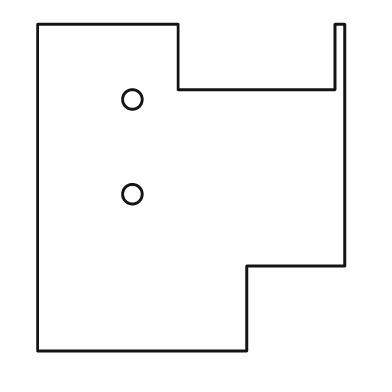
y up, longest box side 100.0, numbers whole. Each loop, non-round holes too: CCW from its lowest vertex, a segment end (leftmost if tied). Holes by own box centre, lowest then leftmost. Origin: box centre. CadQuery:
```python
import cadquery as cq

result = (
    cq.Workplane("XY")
    .moveTo(-47.0, -50.0)
    .lineTo(17.0, -50.0)
    .lineTo(17.0, -24.0)
    .lineTo(47.0, -24.0)
    .lineTo(47.0, 50.0)
    .lineTo(44.0, 50.0)
    .lineTo(44.0, 30.0)
    .lineTo(-4.0, 30.0)
    .lineTo(-4.0, 50.0)
    .lineTo(-47.0, 50.0)
    .close()
    .moveTo(-18.0, -2.0)
    .circle(3.0)
    .moveTo(-18.0, 27.0)
    .circle(3.0)
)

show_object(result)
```